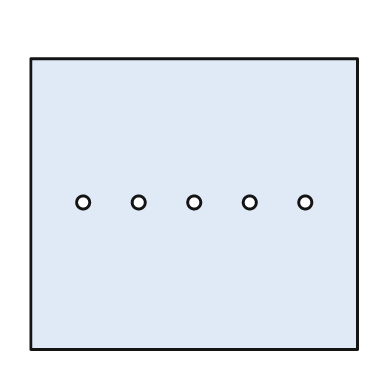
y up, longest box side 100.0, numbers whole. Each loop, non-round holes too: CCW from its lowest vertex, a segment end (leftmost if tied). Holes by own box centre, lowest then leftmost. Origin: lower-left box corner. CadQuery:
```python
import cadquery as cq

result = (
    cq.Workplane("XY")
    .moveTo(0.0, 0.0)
    .lineTo(100.0, 0.0)
    .lineTo(100.0, 89.0)
    .lineTo(0.0, 89.0)
    .close()
    .moveTo(16.0, 45.0)
    .circle(2.0)
    .moveTo(33.0, 45.0)
    .circle(2.0)
    .moveTo(50.0, 45.0)
    .circle(2.0)
    .moveTo(67.0, 45.0)
    .circle(2.0)
    .moveTo(84.0, 45.0)
    .circle(2.0)
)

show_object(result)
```